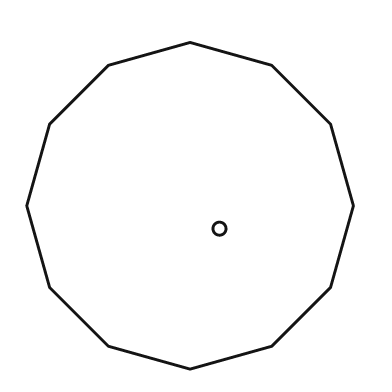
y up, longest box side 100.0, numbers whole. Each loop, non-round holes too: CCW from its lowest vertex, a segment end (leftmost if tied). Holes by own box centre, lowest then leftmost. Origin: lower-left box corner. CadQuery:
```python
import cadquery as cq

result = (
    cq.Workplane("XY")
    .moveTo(50.0, 0.0)
    .lineTo(75.0, 7.0)
    .lineTo(93.0, 25.0)
    .lineTo(100.0, 50.0)
    .lineTo(93.0, 75.0)
    .lineTo(75.0, 93.0)
    .lineTo(50.0, 100.0)
    .lineTo(25.0, 93.0)
    .lineTo(7.0, 75.0)
    .lineTo(0.0, 50.0)
    .lineTo(7.0, 25.0)
    .lineTo(25.0, 7.0)
    .close()
    .moveTo(59.0, 43.0)
    .circle(2.0)
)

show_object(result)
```